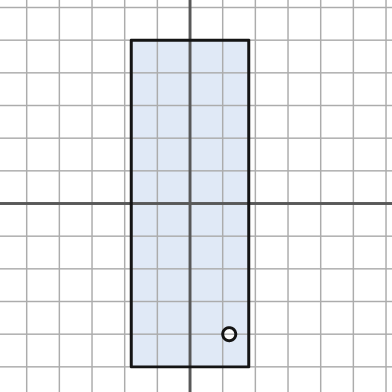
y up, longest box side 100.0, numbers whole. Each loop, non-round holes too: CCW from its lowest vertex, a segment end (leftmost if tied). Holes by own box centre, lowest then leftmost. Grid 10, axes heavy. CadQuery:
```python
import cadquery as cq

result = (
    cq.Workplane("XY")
    .moveTo(-18.0, -50.0)
    .lineTo(18.0, -50.0)
    .lineTo(18.0, 50.0)
    .lineTo(-18.0, 50.0)
    .close()
    .moveTo(12.0, -40.0)
    .circle(2.0)
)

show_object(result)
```